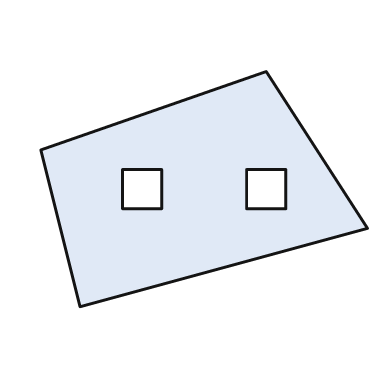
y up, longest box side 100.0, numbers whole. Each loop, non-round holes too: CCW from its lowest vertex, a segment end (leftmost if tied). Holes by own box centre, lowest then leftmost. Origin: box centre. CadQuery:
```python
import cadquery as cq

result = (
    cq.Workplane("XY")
    .moveTo(-38.0, -36.0)
    .lineTo(50.0, -12.0)
    .lineTo(19.0, 36.0)
    .lineTo(-50.0, 12.0)
    .close()
    .moveTo(-25.0, -6.0)
    .lineTo(-13.0, -6.0)
    .lineTo(-13.0, 6.0)
    .lineTo(-25.0, 6.0)
    .close()
    .moveTo(13.0, -6.0)
    .lineTo(25.0, -6.0)
    .lineTo(25.0, 6.0)
    .lineTo(13.0, 6.0)
    .close()
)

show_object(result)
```